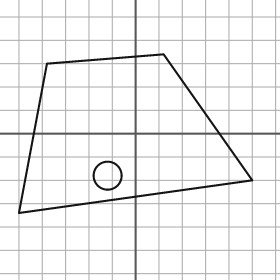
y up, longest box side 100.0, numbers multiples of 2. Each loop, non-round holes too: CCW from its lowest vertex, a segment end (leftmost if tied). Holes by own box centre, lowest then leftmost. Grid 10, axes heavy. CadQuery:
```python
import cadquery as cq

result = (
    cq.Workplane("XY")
    .moveTo(-50.0, -34.0)
    .lineTo(50.0, -20.0)
    .lineTo(12.0, 34.0)
    .lineTo(-38.0, 30.0)
    .close()
    .moveTo(-12.0, -18.0)
    .circle(6.0)
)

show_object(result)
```